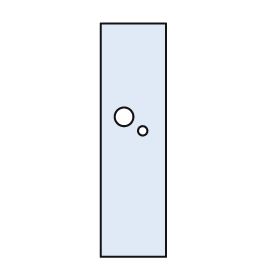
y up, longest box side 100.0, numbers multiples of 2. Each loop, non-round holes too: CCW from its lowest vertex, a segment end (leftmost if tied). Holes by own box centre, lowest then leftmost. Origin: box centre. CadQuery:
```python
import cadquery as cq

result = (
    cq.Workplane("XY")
    .moveTo(-14.0, -50.0)
    .lineTo(14.0, -50.0)
    .lineTo(14.0, 50.0)
    .lineTo(-14.0, 50.0)
    .close()
    .moveTo(4.0, 4.0)
    .circle(2.0)
    .moveTo(-4.0, 10.0)
    .circle(4.0)
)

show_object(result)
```